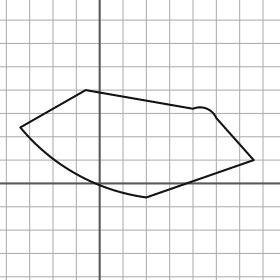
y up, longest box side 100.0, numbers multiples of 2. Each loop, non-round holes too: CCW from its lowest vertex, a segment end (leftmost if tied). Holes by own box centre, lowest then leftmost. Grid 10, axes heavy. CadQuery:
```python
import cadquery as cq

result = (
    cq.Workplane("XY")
    .moveTo(20.0, -6.0)
    .lineTo(66.0, 10.0)
    .lineTo(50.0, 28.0)
    .threePointArc((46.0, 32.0), (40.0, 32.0))
    .lineTo(-6.0, 40.0)
    .lineTo(-34.0, 24.0)
    .threePointArc((-10.0, 4.0), (20.0, -6.0))
    .close()
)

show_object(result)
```